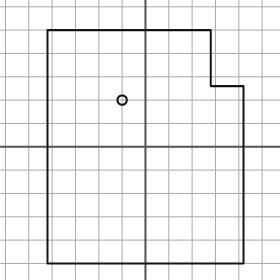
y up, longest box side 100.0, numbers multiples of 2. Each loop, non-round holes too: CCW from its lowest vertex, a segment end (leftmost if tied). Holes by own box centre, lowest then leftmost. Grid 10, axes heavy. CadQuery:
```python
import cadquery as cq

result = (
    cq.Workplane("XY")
    .moveTo(-42.0, -50.0)
    .lineTo(42.0, -50.0)
    .lineTo(42.0, 26.0)
    .lineTo(28.0, 26.0)
    .lineTo(28.0, 50.0)
    .lineTo(-42.0, 50.0)
    .close()
    .moveTo(-10.0, 20.0)
    .circle(2.0)
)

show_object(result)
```